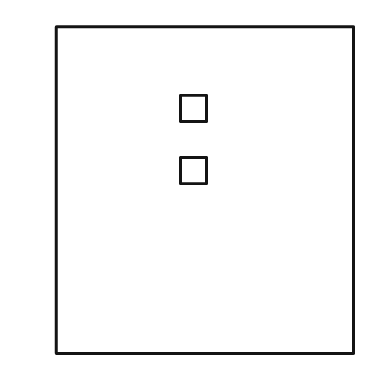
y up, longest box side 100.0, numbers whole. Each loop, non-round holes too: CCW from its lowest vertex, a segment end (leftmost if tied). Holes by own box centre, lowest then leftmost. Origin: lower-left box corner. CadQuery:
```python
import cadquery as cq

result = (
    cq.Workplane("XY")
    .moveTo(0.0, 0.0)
    .lineTo(91.0, 0.0)
    .lineTo(91.0, 100.0)
    .lineTo(0.0, 100.0)
    .close()
    .moveTo(38.0, 52.0)
    .lineTo(46.0, 52.0)
    .lineTo(46.0, 60.0)
    .lineTo(38.0, 60.0)
    .close()
    .moveTo(38.0, 71.0)
    .lineTo(46.0, 71.0)
    .lineTo(46.0, 79.0)
    .lineTo(38.0, 79.0)
    .close()
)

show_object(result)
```